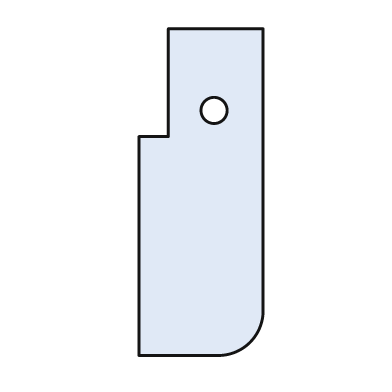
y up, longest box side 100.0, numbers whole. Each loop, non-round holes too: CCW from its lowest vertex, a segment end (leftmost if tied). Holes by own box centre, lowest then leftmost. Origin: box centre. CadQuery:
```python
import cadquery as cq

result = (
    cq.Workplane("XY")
    .moveTo(-19.0, -50.0)
    .lineTo(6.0, -50.0)
    .threePointArc((15.0, -46.0), (19.0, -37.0))
    .lineTo(19.0, 50.0)
    .lineTo(-10.0, 50.0)
    .lineTo(-10.0, 17.0)
    .lineTo(-19.0, 17.0)
    .close()
    .moveTo(4.0, 25.0)
    .circle(4.0)
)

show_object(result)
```